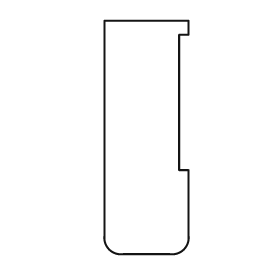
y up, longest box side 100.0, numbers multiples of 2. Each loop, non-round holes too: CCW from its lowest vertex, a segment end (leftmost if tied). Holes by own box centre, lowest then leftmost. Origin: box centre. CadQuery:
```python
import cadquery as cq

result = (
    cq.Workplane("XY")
    .moveTo(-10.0, -50.0)
    .lineTo(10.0, -50.0)
    .threePointArc((16.0, -48.0), (18.0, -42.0))
    .lineTo(18.0, -14.0)
    .lineTo(14.0, -14.0)
    .lineTo(14.0, 44.0)
    .lineTo(18.0, 44.0)
    .lineTo(18.0, 50.0)
    .lineTo(-18.0, 50.0)
    .lineTo(-18.0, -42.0)
    .threePointArc((-16.0, -48.0), (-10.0, -50.0))
    .close()
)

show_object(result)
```